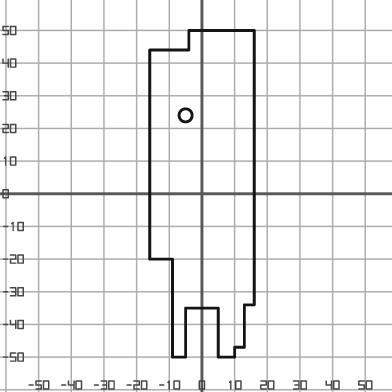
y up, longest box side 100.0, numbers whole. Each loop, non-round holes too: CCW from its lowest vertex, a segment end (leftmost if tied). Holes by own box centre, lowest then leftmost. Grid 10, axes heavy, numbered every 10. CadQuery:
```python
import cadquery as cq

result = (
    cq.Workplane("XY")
    .moveTo(-9.0, -50.0)
    .lineTo(-5.0, -50.0)
    .lineTo(-5.0, -35.0)
    .lineTo(5.0, -35.0)
    .lineTo(5.0, -50.0)
    .lineTo(10.0, -50.0)
    .lineTo(10.0, -47.0)
    .lineTo(13.0, -47.0)
    .lineTo(13.0, -34.0)
    .lineTo(16.0, -34.0)
    .lineTo(16.0, 50.0)
    .lineTo(-4.0, 50.0)
    .lineTo(-4.0, 44.0)
    .lineTo(-16.0, 44.0)
    .lineTo(-16.0, -20.0)
    .lineTo(-9.0, -20.0)
    .close()
    .moveTo(-5.0, 24.0)
    .circle(2.0)
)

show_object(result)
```